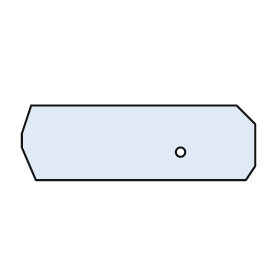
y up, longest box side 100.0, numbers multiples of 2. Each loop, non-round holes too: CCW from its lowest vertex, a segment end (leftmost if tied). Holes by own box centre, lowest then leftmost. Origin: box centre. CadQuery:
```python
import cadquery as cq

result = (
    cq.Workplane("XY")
    .moveTo(-44.0, -16.0)
    .lineTo(46.0, -16.0)
    .lineTo(50.0, -10.0)
    .lineTo(50.0, 8.0)
    .lineTo(42.0, 16.0)
    .lineTo(-46.0, 16.0)
    .lineTo(-50.0, 4.0)
    .lineTo(-50.0, -2.0)
    .close()
    .moveTo(18.0, -4.0)
    .circle(2.0)
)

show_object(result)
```